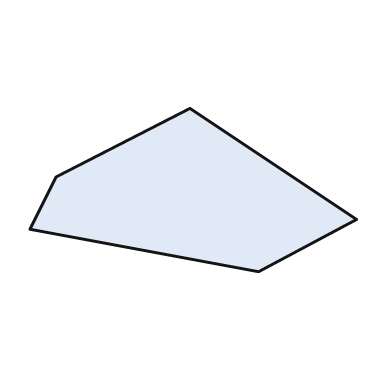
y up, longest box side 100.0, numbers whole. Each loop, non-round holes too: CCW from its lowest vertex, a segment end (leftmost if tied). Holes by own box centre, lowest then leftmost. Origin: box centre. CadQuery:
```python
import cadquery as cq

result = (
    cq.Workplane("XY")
    .moveTo(20.0, -25.0)
    .lineTo(50.0, -9.0)
    .lineTo(-1.0, 25.0)
    .lineTo(-42.0, 4.0)
    .lineTo(-50.0, -12.0)
    .close()
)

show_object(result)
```